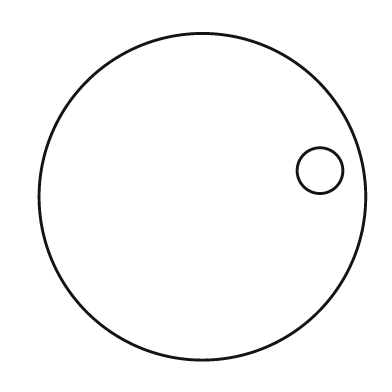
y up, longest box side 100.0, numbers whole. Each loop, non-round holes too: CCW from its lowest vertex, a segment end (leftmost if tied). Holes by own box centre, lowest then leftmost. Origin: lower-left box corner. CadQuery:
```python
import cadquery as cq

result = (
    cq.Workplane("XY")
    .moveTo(50.0, 50.0)
    .circle(50.0)
    .moveTo(86.0, 58.0)
    .circle(7.0)
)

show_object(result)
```